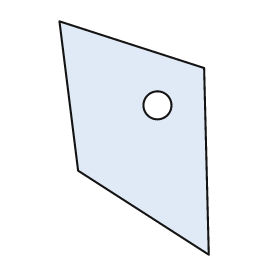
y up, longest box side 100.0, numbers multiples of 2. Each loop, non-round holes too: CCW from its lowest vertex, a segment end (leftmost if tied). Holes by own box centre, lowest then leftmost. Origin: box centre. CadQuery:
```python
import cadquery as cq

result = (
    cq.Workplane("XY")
    .moveTo(32.0, -50.0)
    .lineTo(30.0, 30.0)
    .lineTo(-32.0, 50.0)
    .lineTo(-24.0, -14.0)
    .close()
    .moveTo(10.0, 14.0)
    .circle(6.0)
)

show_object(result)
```